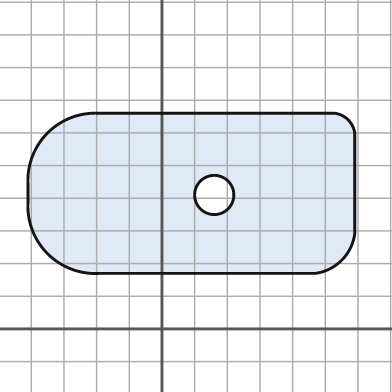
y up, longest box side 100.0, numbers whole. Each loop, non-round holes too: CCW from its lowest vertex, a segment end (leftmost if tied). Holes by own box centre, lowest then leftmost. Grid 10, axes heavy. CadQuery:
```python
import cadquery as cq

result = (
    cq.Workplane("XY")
    .moveTo(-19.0, 17.0)
    .lineTo(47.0, 17.0)
    .threePointArc((55.0, 21.0), (59.0, 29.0))
    .lineTo(59.0, 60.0)
    .threePointArc((57.0, 64.0), (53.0, 66.0))
    .lineTo(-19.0, 66.0)
    .threePointArc((-35.0, 60.0), (-41.0, 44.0))
    .lineTo(-41.0, 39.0)
    .threePointArc((-35.0, 23.0), (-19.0, 17.0))
    .close()
    .moveTo(16.0, 41.0)
    .circle(6.0)
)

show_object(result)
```